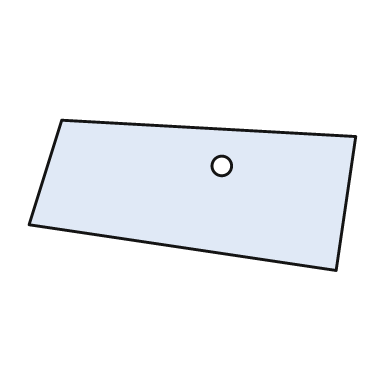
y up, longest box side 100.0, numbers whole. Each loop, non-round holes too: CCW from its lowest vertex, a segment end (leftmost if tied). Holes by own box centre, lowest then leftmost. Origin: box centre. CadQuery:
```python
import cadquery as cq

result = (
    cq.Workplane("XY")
    .moveTo(44.0, -23.0)
    .lineTo(50.0, 18.0)
    .lineTo(-40.0, 23.0)
    .lineTo(-50.0, -9.0)
    .close()
    .moveTo(9.0, 9.0)
    .circle(3.0)
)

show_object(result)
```